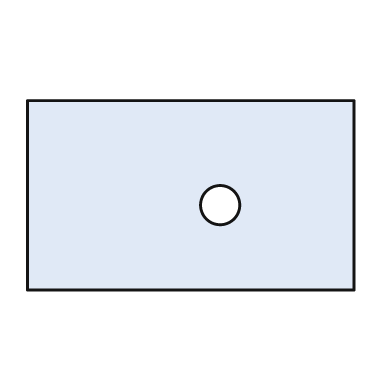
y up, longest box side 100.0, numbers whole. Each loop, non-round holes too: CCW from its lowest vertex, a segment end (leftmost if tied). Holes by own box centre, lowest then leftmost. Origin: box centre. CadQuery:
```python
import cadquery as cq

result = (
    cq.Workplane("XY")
    .moveTo(-50.0, -29.0)
    .lineTo(50.0, -29.0)
    .lineTo(50.0, 29.0)
    .lineTo(-50.0, 29.0)
    .close()
    .moveTo(9.0, -3.0)
    .circle(6.0)
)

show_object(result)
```